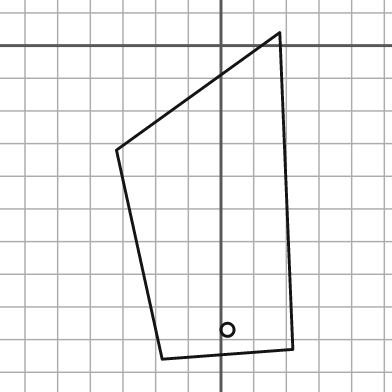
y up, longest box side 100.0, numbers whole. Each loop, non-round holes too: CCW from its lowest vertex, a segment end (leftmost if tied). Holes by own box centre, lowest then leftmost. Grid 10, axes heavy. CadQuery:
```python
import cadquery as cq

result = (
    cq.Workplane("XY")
    .moveTo(-18.0, -96.0)
    .lineTo(22.0, -93.0)
    .lineTo(18.0, 4.0)
    .lineTo(-32.0, -32.0)
    .close()
    .moveTo(2.0, -87.0)
    .circle(2.0)
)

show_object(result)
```